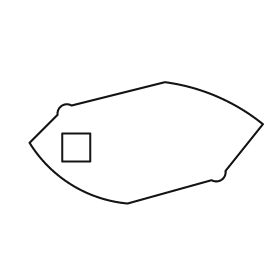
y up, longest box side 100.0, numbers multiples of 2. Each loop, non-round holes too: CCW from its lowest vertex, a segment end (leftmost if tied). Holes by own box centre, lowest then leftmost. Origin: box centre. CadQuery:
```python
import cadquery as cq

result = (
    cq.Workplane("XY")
    .moveTo(-8.0, -26.0)
    .lineTo(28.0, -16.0)
    .threePointArc((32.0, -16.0), (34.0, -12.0))
    .lineTo(50.0, 8.0)
    .threePointArc((30.0, 20.0), (8.0, 26.0))
    .lineTo(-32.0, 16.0)
    .threePointArc((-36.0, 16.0), (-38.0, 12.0))
    .lineTo(-50.0, 0.0)
    .threePointArc((-32.0, -18.0), (-8.0, -26.0))
    .close()
    .moveTo(-36.0, -8.0)
    .lineTo(-24.0, -8.0)
    .lineTo(-24.0, 4.0)
    .lineTo(-36.0, 4.0)
    .close()
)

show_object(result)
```